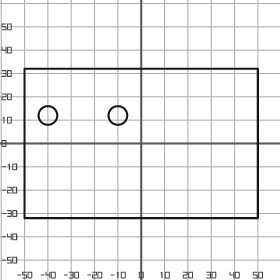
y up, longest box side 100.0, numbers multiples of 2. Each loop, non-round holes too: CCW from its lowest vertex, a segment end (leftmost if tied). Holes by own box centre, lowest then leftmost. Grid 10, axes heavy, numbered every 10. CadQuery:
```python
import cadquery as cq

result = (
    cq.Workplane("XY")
    .moveTo(-50.0, -32.0)
    .lineTo(50.0, -32.0)
    .lineTo(50.0, 32.0)
    .lineTo(-50.0, 32.0)
    .close()
    .moveTo(-40.0, 12.0)
    .circle(4.0)
    .moveTo(-10.0, 12.0)
    .circle(4.0)
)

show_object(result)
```